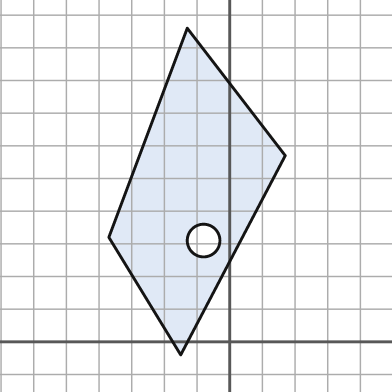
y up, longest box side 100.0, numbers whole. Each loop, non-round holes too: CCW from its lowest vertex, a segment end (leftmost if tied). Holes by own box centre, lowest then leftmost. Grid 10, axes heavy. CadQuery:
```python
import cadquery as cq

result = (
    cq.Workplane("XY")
    .moveTo(-15.0, -4.0)
    .lineTo(17.0, 57.0)
    .lineTo(-13.0, 96.0)
    .lineTo(-37.0, 32.0)
    .close()
    .moveTo(-8.0, 31.0)
    .circle(5.0)
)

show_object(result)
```